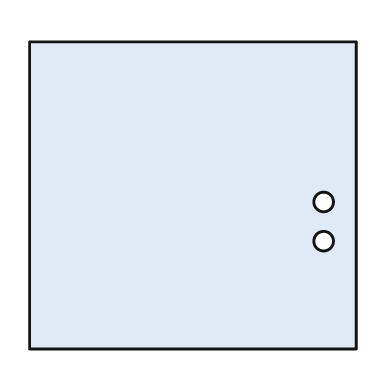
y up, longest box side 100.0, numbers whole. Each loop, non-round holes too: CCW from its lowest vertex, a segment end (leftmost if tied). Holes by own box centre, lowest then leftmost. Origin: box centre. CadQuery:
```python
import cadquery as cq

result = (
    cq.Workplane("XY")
    .moveTo(-50.0, -47.0)
    .lineTo(50.0, -47.0)
    .lineTo(50.0, 47.0)
    .lineTo(-50.0, 47.0)
    .close()
    .moveTo(40.0, -14.0)
    .circle(3.0)
    .moveTo(40.0, -2.0)
    .circle(3.0)
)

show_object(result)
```